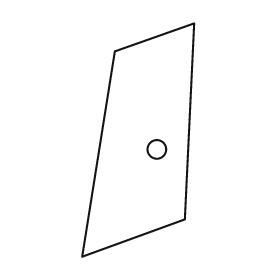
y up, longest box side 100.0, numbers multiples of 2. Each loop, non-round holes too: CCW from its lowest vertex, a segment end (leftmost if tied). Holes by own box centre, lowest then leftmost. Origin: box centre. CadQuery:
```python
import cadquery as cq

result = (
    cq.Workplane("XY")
    .moveTo(-24.0, -50.0)
    .lineTo(20.0, -34.0)
    .lineTo(24.0, 50.0)
    .lineTo(-10.0, 38.0)
    .close()
    .moveTo(8.0, -4.0)
    .circle(4.0)
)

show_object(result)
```